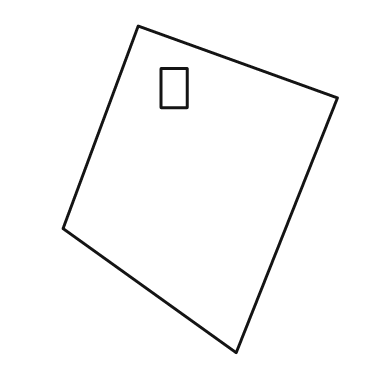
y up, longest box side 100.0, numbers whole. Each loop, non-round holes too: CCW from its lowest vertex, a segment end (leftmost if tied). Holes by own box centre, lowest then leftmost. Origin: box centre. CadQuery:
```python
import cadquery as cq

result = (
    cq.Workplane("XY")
    .moveTo(11.0, -50.0)
    .lineTo(42.0, 28.0)
    .lineTo(-19.0, 50.0)
    .lineTo(-42.0, -12.0)
    .close()
    .moveTo(-12.0, 25.0)
    .lineTo(-4.0, 25.0)
    .lineTo(-4.0, 37.0)
    .lineTo(-12.0, 37.0)
    .close()
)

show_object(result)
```